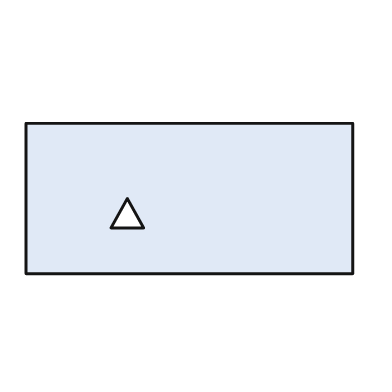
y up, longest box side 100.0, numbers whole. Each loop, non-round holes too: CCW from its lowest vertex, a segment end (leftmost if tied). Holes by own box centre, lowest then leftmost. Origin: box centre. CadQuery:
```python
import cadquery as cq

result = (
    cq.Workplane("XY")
    .moveTo(-50.0, -23.0)
    .lineTo(50.0, -23.0)
    .lineTo(50.0, 23.0)
    .lineTo(-50.0, 23.0)
    .close()
    .moveTo(-24.0, -9.0)
    .lineTo(-14.0, -9.0)
    .lineTo(-19.0, 0.0)
    .close()
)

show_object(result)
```